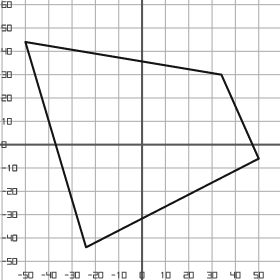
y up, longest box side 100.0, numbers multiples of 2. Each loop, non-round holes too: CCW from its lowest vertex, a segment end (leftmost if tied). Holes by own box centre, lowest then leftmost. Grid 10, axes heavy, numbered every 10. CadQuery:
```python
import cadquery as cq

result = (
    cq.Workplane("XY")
    .moveTo(-24.0, -44.0)
    .lineTo(50.0, -6.0)
    .lineTo(34.0, 30.0)
    .lineTo(-50.0, 44.0)
    .close()
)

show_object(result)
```